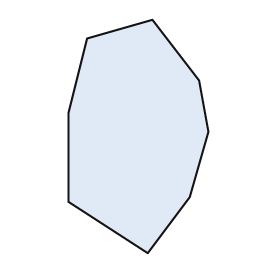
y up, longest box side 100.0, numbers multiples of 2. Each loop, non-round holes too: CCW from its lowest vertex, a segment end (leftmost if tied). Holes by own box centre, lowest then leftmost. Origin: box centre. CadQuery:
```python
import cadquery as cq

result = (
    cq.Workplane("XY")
    .moveTo(4.0, -50.0)
    .lineTo(22.0, -26.0)
    .lineTo(30.0, 2.0)
    .lineTo(26.0, 24.0)
    .lineTo(6.0, 50.0)
    .lineTo(-22.0, 42.0)
    .lineTo(-30.0, 10.0)
    .lineTo(-30.0, -28.0)
    .close()
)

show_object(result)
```